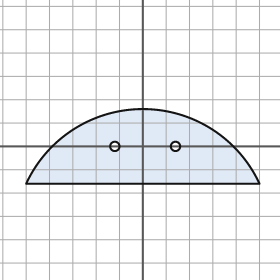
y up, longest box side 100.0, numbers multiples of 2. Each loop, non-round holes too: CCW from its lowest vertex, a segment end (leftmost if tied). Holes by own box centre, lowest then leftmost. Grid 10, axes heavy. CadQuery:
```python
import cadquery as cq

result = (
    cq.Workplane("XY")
    .moveTo(-50.0, -16.0)
    .lineTo(50.0, -16.0)
    .threePointArc((0.0, 16.0), (-50.0, -16.0))
    .close()
    .moveTo(-12.0, 0.0)
    .circle(2.0)
    .moveTo(14.0, 0.0)
    .circle(2.0)
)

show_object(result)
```